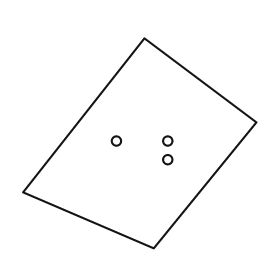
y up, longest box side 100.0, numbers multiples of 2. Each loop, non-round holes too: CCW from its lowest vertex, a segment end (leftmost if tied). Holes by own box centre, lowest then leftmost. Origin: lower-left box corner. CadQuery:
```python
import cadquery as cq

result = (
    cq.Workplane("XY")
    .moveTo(56.0, 0.0)
    .lineTo(100.0, 54.0)
    .lineTo(52.0, 90.0)
    .lineTo(0.0, 24.0)
    .close()
    .moveTo(62.0, 38.0)
    .circle(2.0)
    .moveTo(40.0, 46.0)
    .circle(2.0)
    .moveTo(62.0, 46.0)
    .circle(2.0)
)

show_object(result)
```